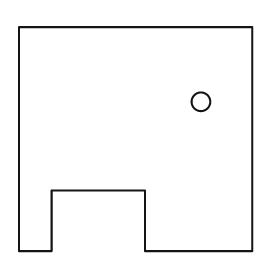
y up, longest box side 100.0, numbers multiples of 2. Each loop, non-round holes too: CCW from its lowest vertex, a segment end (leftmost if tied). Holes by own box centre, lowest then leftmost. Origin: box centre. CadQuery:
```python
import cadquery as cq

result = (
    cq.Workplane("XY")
    .moveTo(-50.0, -48.0)
    .lineTo(-36.0, -48.0)
    .lineTo(-36.0, -22.0)
    .lineTo(4.0, -22.0)
    .lineTo(4.0, -48.0)
    .lineTo(50.0, -48.0)
    .lineTo(50.0, 48.0)
    .lineTo(-50.0, 48.0)
    .close()
    .moveTo(28.0, 16.0)
    .circle(4.0)
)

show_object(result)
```